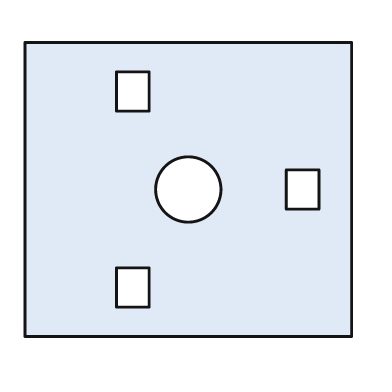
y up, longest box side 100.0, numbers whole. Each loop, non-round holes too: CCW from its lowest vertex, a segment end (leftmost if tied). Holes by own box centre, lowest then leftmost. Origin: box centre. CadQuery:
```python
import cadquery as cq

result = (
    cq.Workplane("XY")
    .moveTo(-50.0, -45.0)
    .lineTo(50.0, -45.0)
    .lineTo(50.0, 45.0)
    .lineTo(-50.0, 45.0)
    .close()
    .moveTo(-22.0, -36.0)
    .lineTo(-12.0, -36.0)
    .lineTo(-12.0, -24.0)
    .lineTo(-22.0, -24.0)
    .close()
    .moveTo(0.0, 0.0)
    .circle(10.0)
    .moveTo(30.0, -6.0)
    .lineTo(40.0, -6.0)
    .lineTo(40.0, 6.0)
    .lineTo(30.0, 6.0)
    .close()
    .moveTo(-22.0, 24.0)
    .lineTo(-12.0, 24.0)
    .lineTo(-12.0, 36.0)
    .lineTo(-22.0, 36.0)
    .close()
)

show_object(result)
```